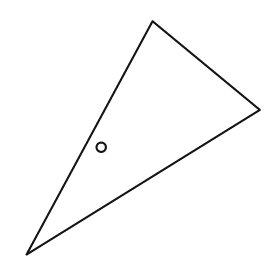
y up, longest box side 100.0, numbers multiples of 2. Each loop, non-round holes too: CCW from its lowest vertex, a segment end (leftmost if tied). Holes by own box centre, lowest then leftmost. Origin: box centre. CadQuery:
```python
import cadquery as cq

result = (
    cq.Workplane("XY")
    .moveTo(-50.0, -50.0)
    .lineTo(50.0, 12.0)
    .lineTo(4.0, 50.0)
    .close()
    .moveTo(-18.0, -4.0)
    .circle(2.0)
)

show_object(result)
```